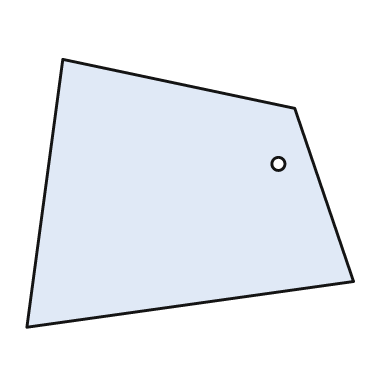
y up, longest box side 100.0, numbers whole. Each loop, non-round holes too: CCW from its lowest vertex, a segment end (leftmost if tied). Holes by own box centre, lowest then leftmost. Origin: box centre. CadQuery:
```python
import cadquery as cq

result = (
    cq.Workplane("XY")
    .moveTo(-50.0, -41.0)
    .lineTo(50.0, -27.0)
    .lineTo(32.0, 26.0)
    .lineTo(-39.0, 41.0)
    .close()
    .moveTo(27.0, 9.0)
    .circle(2.0)
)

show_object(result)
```